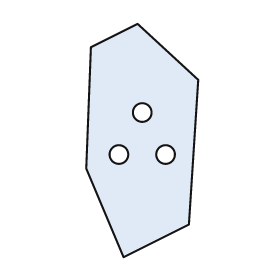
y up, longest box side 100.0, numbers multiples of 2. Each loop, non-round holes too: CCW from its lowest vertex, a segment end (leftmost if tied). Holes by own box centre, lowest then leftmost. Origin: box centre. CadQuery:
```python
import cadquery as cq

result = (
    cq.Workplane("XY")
    .moveTo(-8.0, -50.0)
    .lineTo(20.0, -36.0)
    .lineTo(24.0, 26.0)
    .lineTo(-2.0, 50.0)
    .lineTo(-22.0, 40.0)
    .lineTo(-24.0, -12.0)
    .close()
    .moveTo(-10.0, -6.0)
    .circle(4.0)
    .moveTo(10.0, -6.0)
    .circle(4.0)
    .moveTo(0.0, 12.0)
    .circle(4.0)
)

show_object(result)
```